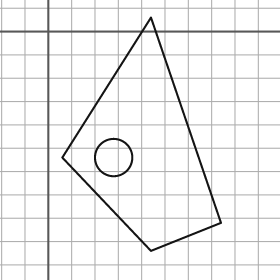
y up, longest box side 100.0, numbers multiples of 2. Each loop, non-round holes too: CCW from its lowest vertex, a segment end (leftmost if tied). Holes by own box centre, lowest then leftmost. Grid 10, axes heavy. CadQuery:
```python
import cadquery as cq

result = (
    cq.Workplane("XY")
    .moveTo(44.0, -94.0)
    .lineTo(74.0, -82.0)
    .lineTo(44.0, 6.0)
    .lineTo(6.0, -54.0)
    .close()
    .moveTo(28.0, -54.0)
    .circle(8.0)
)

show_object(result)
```